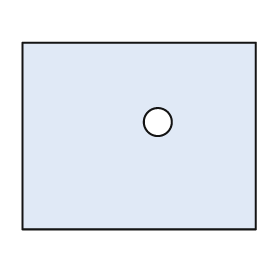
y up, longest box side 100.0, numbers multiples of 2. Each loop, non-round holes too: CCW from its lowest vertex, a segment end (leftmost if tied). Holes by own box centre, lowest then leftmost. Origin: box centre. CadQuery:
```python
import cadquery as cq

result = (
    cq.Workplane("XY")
    .moveTo(-50.0, -40.0)
    .lineTo(50.0, -40.0)
    .lineTo(50.0, 40.0)
    .lineTo(-50.0, 40.0)
    .close()
    .moveTo(8.0, 6.0)
    .circle(6.0)
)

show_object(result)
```